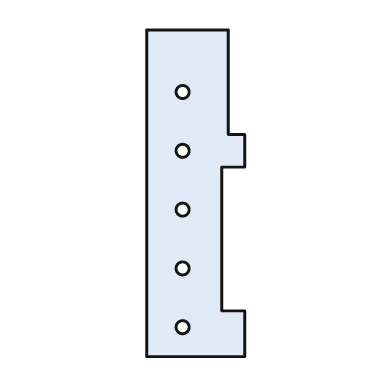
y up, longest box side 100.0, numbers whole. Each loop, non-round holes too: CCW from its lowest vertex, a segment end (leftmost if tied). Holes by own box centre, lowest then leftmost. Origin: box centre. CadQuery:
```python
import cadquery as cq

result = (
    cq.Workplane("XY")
    .moveTo(-15.0, -50.0)
    .lineTo(15.0, -50.0)
    .lineTo(15.0, -36.0)
    .lineTo(8.0, -36.0)
    .lineTo(8.0, 8.0)
    .lineTo(15.0, 8.0)
    .lineTo(15.0, 18.0)
    .lineTo(10.0, 18.0)
    .lineTo(10.0, 50.0)
    .lineTo(-15.0, 50.0)
    .close()
    .moveTo(-4.0, -41.0)
    .circle(2.0)
    .moveTo(-4.0, -23.0)
    .circle(2.0)
    .moveTo(-4.0, -5.0)
    .circle(2.0)
    .moveTo(-4.0, 13.0)
    .circle(2.0)
    .moveTo(-4.0, 31.0)
    .circle(2.0)
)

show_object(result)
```